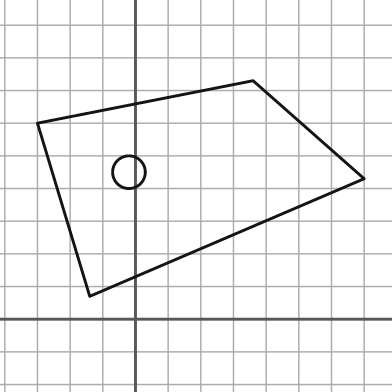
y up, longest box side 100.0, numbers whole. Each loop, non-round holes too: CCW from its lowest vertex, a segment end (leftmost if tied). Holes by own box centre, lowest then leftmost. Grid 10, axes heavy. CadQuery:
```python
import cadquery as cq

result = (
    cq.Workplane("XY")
    .moveTo(-14.0, 7.0)
    .lineTo(70.0, 43.0)
    .lineTo(36.0, 73.0)
    .lineTo(-30.0, 60.0)
    .close()
    .moveTo(-2.0, 45.0)
    .circle(5.0)
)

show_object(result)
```